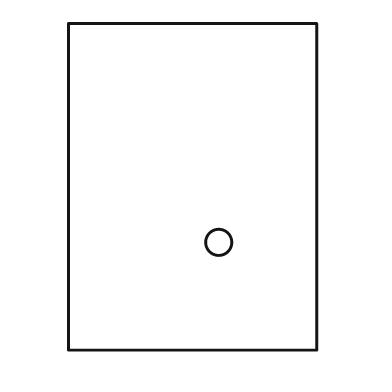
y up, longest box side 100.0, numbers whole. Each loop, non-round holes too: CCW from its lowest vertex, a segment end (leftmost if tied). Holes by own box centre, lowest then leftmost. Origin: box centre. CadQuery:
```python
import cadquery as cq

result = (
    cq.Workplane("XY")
    .moveTo(-38.0, -50.0)
    .lineTo(38.0, -50.0)
    .lineTo(38.0, 50.0)
    .lineTo(-38.0, 50.0)
    .close()
    .moveTo(8.0, -17.0)
    .circle(4.0)
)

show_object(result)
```